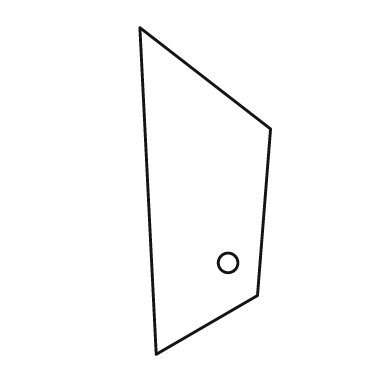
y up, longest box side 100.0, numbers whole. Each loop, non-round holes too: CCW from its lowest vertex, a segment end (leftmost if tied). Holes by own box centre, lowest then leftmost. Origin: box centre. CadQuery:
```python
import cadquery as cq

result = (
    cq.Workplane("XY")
    .moveTo(-15.0, -50.0)
    .lineTo(16.0, -32.0)
    .lineTo(20.0, 19.0)
    .lineTo(-20.0, 50.0)
    .close()
    .moveTo(7.0, -22.0)
    .circle(3.0)
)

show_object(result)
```